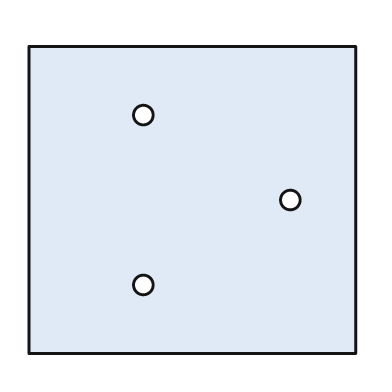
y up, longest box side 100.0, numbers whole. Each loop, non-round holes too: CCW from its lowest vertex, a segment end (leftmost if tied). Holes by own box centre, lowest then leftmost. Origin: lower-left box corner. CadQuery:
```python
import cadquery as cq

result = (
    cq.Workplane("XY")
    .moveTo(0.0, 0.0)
    .lineTo(100.0, 0.0)
    .lineTo(100.0, 94.0)
    .lineTo(0.0, 94.0)
    .close()
    .moveTo(35.0, 21.0)
    .circle(3.0)
    .moveTo(80.0, 47.0)
    .circle(3.0)
    .moveTo(35.0, 73.0)
    .circle(3.0)
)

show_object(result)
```